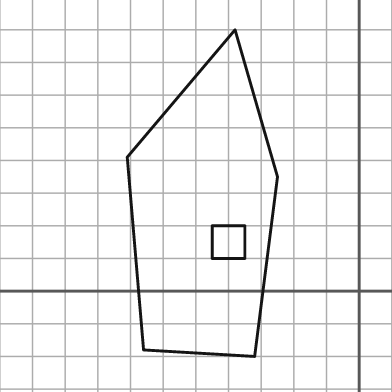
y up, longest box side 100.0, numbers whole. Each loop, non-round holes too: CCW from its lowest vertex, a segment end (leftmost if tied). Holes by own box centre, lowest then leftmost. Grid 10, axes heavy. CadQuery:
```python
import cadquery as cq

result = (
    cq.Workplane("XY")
    .moveTo(-32.0, -20.0)
    .lineTo(-25.0, 35.0)
    .lineTo(-38.0, 80.0)
    .lineTo(-71.0, 41.0)
    .lineTo(-66.0, -18.0)
    .close()
    .moveTo(-45.0, 10.0)
    .lineTo(-35.0, 10.0)
    .lineTo(-35.0, 20.0)
    .lineTo(-45.0, 20.0)
    .close()
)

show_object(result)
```